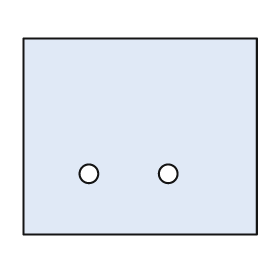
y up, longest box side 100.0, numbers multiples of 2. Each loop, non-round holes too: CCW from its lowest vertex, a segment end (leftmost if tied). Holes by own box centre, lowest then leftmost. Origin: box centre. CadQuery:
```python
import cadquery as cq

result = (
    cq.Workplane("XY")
    .moveTo(-50.0, -42.0)
    .lineTo(50.0, -42.0)
    .lineTo(50.0, 42.0)
    .lineTo(-50.0, 42.0)
    .close()
    .moveTo(-22.0, -16.0)
    .circle(4.0)
    .moveTo(12.0, -16.0)
    .circle(4.0)
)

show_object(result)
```